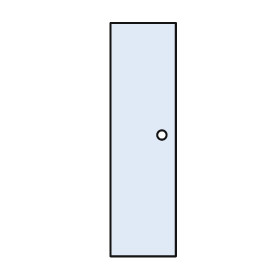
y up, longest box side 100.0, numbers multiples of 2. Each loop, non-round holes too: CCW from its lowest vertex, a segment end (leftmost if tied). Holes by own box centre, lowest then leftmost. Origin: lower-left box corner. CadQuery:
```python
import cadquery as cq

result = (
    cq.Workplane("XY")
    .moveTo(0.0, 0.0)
    .lineTo(28.0, 0.0)
    .lineTo(28.0, 100.0)
    .lineTo(0.0, 100.0)
    .close()
    .moveTo(22.0, 52.0)
    .circle(2.0)
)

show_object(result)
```